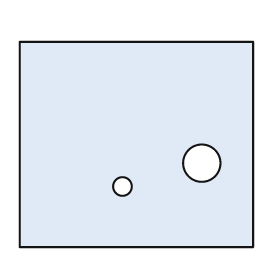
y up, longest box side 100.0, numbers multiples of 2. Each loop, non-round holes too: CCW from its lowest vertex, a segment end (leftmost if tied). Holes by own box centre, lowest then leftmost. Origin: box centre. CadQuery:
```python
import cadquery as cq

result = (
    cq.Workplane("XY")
    .moveTo(-50.0, -44.0)
    .lineTo(50.0, -44.0)
    .lineTo(50.0, 44.0)
    .lineTo(-50.0, 44.0)
    .close()
    .moveTo(-6.0, -18.0)
    .circle(4.0)
    .moveTo(28.0, -8.0)
    .circle(8.0)
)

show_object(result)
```